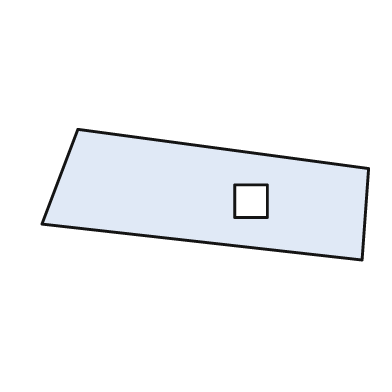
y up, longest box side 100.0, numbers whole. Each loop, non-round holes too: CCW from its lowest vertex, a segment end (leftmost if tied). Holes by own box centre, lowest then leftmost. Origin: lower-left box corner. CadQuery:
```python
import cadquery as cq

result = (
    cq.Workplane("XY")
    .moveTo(98.0, 0.0)
    .lineTo(100.0, 28.0)
    .lineTo(11.0, 40.0)
    .lineTo(0.0, 11.0)
    .close()
    .moveTo(59.0, 13.0)
    .lineTo(69.0, 13.0)
    .lineTo(69.0, 23.0)
    .lineTo(59.0, 23.0)
    .close()
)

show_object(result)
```